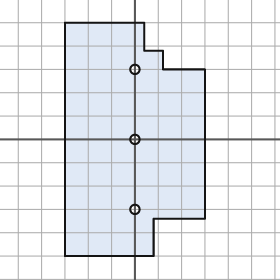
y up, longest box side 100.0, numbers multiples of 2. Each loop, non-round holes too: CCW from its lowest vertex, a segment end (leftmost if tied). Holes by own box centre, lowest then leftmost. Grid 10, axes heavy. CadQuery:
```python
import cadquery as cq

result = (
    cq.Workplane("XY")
    .moveTo(-30.0, -50.0)
    .lineTo(8.0, -50.0)
    .lineTo(8.0, -34.0)
    .lineTo(30.0, -34.0)
    .lineTo(30.0, 30.0)
    .lineTo(12.0, 30.0)
    .lineTo(12.0, 38.0)
    .lineTo(4.0, 38.0)
    .lineTo(4.0, 50.0)
    .lineTo(-30.0, 50.0)
    .close()
    .moveTo(0.0, -30.0)
    .circle(2.0)
    .moveTo(0.0, 0.0)
    .circle(2.0)
    .moveTo(0.0, 30.0)
    .circle(2.0)
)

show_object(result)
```